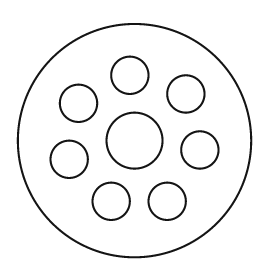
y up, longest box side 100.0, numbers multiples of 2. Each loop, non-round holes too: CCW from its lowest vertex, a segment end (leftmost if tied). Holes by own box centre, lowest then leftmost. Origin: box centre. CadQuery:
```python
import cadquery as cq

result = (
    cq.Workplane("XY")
    .moveTo(0.0, 0.0)
    .circle(50.0)
    .moveTo(-10.0, -26.0)
    .circle(8.0)
    .moveTo(14.0, -26.0)
    .circle(8.0)
    .moveTo(-28.0, -8.0)
    .circle(8.0)
    .moveTo(28.0, -4.0)
    .circle(8.0)
    .moveTo(0.0, 0.0)
    .circle(12.0)
    .moveTo(-24.0, 16.0)
    .circle(8.0)
    .moveTo(22.0, 20.0)
    .circle(8.0)
    .moveTo(-2.0, 28.0)
    .circle(8.0)
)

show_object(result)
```